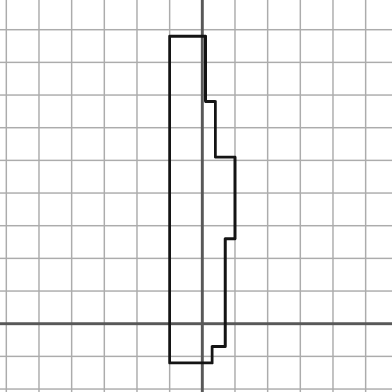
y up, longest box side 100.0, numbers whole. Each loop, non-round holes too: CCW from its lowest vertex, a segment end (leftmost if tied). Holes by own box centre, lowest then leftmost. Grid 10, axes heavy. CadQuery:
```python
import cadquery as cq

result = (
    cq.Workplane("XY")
    .moveTo(-10.0, -12.0)
    .lineTo(3.0, -12.0)
    .lineTo(3.0, -7.0)
    .lineTo(7.0, -7.0)
    .lineTo(7.0, 26.0)
    .lineTo(10.0, 26.0)
    .lineTo(10.0, 51.0)
    .lineTo(4.0, 51.0)
    .lineTo(4.0, 68.0)
    .lineTo(1.0, 68.0)
    .lineTo(1.0, 88.0)
    .lineTo(-10.0, 88.0)
    .close()
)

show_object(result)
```